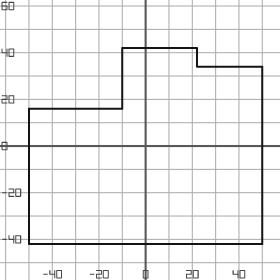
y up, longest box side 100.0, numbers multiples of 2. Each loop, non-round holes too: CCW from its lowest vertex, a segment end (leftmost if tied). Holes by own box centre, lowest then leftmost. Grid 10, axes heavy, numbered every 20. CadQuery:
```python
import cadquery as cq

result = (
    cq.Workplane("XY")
    .moveTo(-50.0, -42.0)
    .lineTo(50.0, -42.0)
    .lineTo(50.0, 34.0)
    .lineTo(22.0, 34.0)
    .lineTo(22.0, 42.0)
    .lineTo(-10.0, 42.0)
    .lineTo(-10.0, 16.0)
    .lineTo(-50.0, 16.0)
    .close()
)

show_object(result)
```